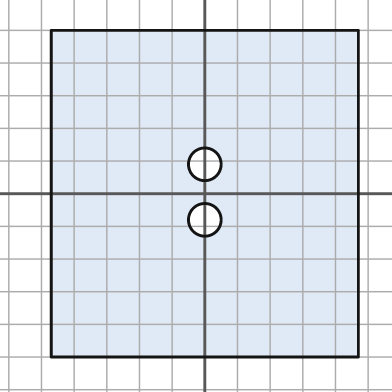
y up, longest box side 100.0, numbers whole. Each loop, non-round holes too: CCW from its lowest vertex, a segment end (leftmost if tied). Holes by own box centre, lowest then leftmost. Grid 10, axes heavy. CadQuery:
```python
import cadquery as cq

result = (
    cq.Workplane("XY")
    .moveTo(-47.0, -50.0)
    .lineTo(47.0, -50.0)
    .lineTo(47.0, 50.0)
    .lineTo(-47.0, 50.0)
    .close()
    .moveTo(0.0, -8.0)
    .circle(5.0)
    .moveTo(0.0, 9.0)
    .circle(5.0)
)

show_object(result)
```